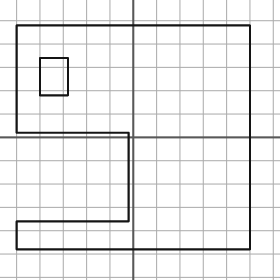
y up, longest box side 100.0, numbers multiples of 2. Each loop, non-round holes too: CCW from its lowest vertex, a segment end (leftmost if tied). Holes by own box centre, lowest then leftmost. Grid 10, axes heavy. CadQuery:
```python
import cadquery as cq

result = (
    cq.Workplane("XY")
    .moveTo(-50.0, -48.0)
    .lineTo(50.0, -48.0)
    .lineTo(50.0, 48.0)
    .lineTo(-50.0, 48.0)
    .lineTo(-50.0, 2.0)
    .lineTo(-2.0, 2.0)
    .lineTo(-2.0, -36.0)
    .lineTo(-50.0, -36.0)
    .close()
    .moveTo(-40.0, 18.0)
    .lineTo(-28.0, 18.0)
    .lineTo(-28.0, 34.0)
    .lineTo(-40.0, 34.0)
    .close()
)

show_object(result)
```